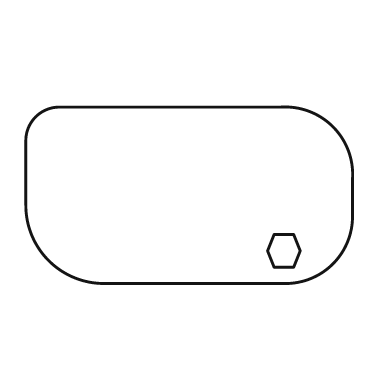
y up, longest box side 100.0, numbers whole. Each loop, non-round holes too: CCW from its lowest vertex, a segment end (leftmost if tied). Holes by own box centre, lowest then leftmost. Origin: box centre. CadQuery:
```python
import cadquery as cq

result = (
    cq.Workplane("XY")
    .moveTo(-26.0, -27.0)
    .lineTo(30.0, -27.0)
    .threePointArc((44.0, -21.0), (50.0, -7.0))
    .lineTo(50.0, 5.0)
    .threePointArc((44.0, 21.0), (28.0, 27.0))
    .lineTo(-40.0, 27.0)
    .threePointArc((-47.0, 24.0), (-50.0, 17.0))
    .lineTo(-50.0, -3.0)
    .threePointArc((-43.0, -20.0), (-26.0, -27.0))
    .close()
    .moveTo(26.0, -22.0)
    .lineTo(32.0, -22.0)
    .lineTo(34.0, -17.0)
    .lineTo(32.0, -12.0)
    .lineTo(26.0, -12.0)
    .lineTo(24.0, -17.0)
    .close()
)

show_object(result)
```